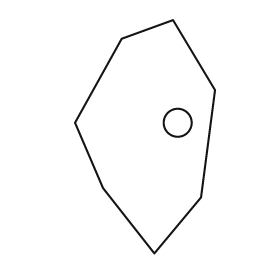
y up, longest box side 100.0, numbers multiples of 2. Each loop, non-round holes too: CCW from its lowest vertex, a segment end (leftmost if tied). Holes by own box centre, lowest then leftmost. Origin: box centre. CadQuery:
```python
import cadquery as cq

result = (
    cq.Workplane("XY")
    .moveTo(4.0, -50.0)
    .lineTo(24.0, -26.0)
    .lineTo(30.0, 20.0)
    .lineTo(12.0, 50.0)
    .lineTo(-10.0, 42.0)
    .lineTo(-30.0, 6.0)
    .lineTo(-18.0, -22.0)
    .close()
    .moveTo(14.0, 6.0)
    .circle(6.0)
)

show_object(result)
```